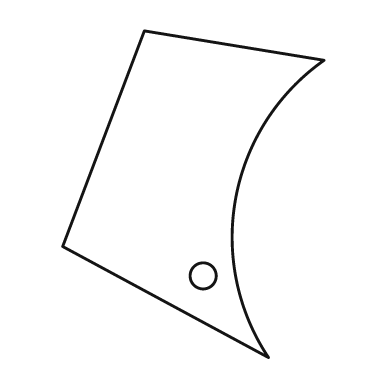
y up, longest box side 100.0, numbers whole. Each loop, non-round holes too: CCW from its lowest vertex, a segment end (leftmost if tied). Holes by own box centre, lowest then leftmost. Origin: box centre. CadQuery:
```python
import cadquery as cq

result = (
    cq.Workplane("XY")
    .moveTo(23.0, -50.0)
    .threePointArc((13.0, -1.0), (40.0, 41.0))
    .lineTo(-15.0, 50.0)
    .lineTo(-40.0, -16.0)
    .close()
    .moveTo(3.0, -25.0)
    .circle(4.0)
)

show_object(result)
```